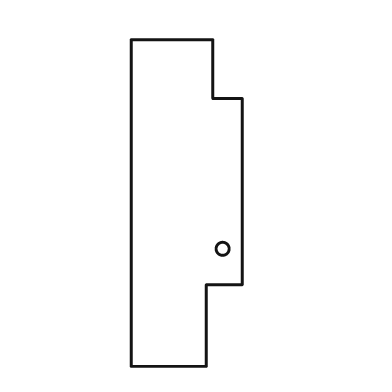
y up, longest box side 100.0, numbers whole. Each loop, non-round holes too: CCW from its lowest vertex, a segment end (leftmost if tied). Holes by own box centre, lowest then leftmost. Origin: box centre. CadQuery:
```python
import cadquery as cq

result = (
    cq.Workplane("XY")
    .moveTo(-17.0, -50.0)
    .lineTo(6.0, -50.0)
    .lineTo(6.0, -25.0)
    .lineTo(17.0, -25.0)
    .lineTo(17.0, 32.0)
    .lineTo(8.0, 32.0)
    .lineTo(8.0, 50.0)
    .lineTo(-17.0, 50.0)
    .close()
    .moveTo(11.0, -14.0)
    .circle(2.0)
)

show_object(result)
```